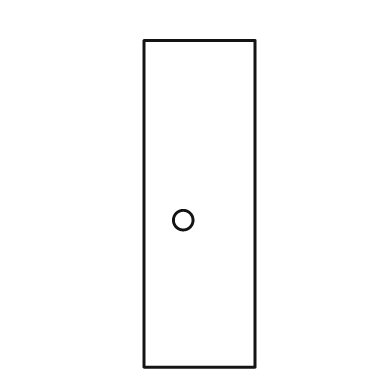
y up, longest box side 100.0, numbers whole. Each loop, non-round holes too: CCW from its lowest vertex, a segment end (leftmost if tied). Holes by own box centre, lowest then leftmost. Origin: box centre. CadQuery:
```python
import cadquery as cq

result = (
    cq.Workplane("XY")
    .moveTo(-17.0, -50.0)
    .lineTo(17.0, -50.0)
    .lineTo(17.0, 50.0)
    .lineTo(-17.0, 50.0)
    .close()
    .moveTo(-5.0, -5.0)
    .circle(3.0)
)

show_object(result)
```